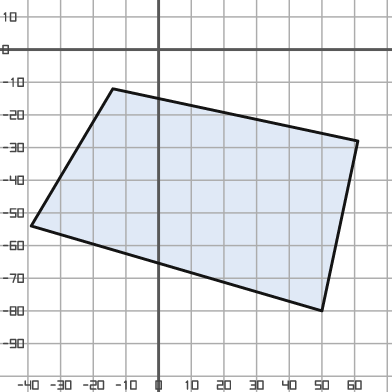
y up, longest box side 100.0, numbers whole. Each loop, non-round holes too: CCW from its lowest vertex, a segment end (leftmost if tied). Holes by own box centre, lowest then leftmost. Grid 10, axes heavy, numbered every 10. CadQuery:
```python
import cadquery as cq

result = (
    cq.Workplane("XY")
    .moveTo(50.0, -80.0)
    .lineTo(61.0, -28.0)
    .lineTo(-14.0, -12.0)
    .lineTo(-39.0, -54.0)
    .close()
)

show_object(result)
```